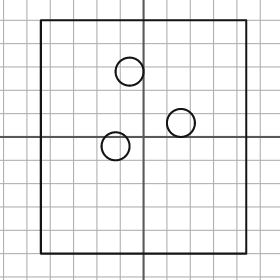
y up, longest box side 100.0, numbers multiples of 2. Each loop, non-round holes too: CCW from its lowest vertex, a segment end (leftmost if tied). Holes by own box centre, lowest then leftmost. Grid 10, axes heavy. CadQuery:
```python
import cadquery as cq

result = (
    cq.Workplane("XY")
    .moveTo(-44.0, -50.0)
    .lineTo(44.0, -50.0)
    .lineTo(44.0, 50.0)
    .lineTo(-44.0, 50.0)
    .close()
    .moveTo(-12.0, -4.0)
    .circle(6.0)
    .moveTo(16.0, 6.0)
    .circle(6.0)
    .moveTo(-6.0, 28.0)
    .circle(6.0)
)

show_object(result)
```